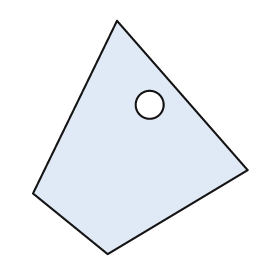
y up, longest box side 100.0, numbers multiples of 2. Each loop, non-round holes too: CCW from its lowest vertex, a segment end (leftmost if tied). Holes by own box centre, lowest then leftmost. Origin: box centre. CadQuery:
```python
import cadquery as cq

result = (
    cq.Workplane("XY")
    .moveTo(-14.0, -50.0)
    .lineTo(46.0, -14.0)
    .lineTo(-10.0, 50.0)
    .lineTo(-46.0, -24.0)
    .close()
    .moveTo(4.0, 14.0)
    .circle(6.0)
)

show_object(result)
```